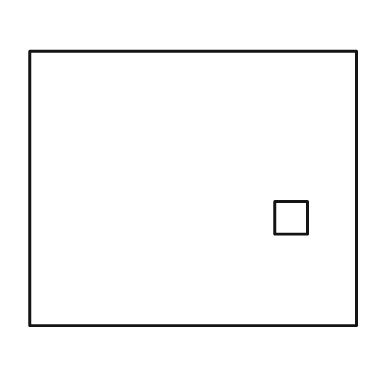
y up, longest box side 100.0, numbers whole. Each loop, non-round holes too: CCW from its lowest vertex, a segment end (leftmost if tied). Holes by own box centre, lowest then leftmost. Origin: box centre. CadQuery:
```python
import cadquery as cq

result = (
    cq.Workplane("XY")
    .moveTo(-50.0, -42.0)
    .lineTo(50.0, -42.0)
    .lineTo(50.0, 42.0)
    .lineTo(-50.0, 42.0)
    .close()
    .moveTo(25.0, -14.0)
    .lineTo(35.0, -14.0)
    .lineTo(35.0, -4.0)
    .lineTo(25.0, -4.0)
    .close()
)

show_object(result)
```